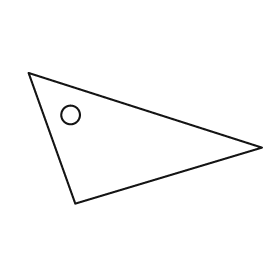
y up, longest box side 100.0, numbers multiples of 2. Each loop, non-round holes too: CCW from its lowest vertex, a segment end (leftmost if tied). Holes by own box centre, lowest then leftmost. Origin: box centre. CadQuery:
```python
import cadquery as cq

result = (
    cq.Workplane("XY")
    .moveTo(-30.0, -28.0)
    .lineTo(50.0, -4.0)
    .lineTo(-50.0, 28.0)
    .close()
    .moveTo(-32.0, 10.0)
    .circle(4.0)
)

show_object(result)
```